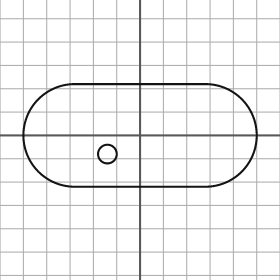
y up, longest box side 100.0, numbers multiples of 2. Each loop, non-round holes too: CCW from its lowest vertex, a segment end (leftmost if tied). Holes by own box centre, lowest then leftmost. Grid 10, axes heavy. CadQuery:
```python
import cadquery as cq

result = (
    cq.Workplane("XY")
    .moveTo(-28.0, -22.0)
    .lineTo(28.0, -22.0)
    .threePointArc((50.0, 0.0), (28.0, 22.0))
    .lineTo(-28.0, 22.0)
    .threePointArc((-50.0, 0.0), (-28.0, -22.0))
    .close()
    .moveTo(-14.0, -8.0)
    .circle(4.0)
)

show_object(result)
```